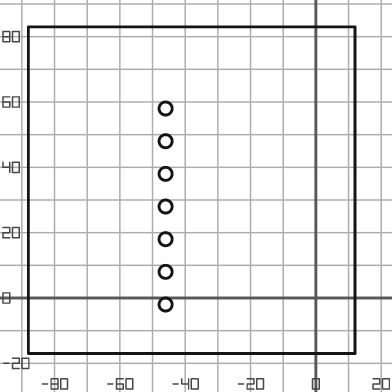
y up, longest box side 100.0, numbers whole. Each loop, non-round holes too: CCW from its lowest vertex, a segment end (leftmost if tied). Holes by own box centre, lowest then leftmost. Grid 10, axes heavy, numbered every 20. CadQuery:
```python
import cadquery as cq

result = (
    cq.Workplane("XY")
    .moveTo(-88.0, -17.0)
    .lineTo(12.0, -17.0)
    .lineTo(12.0, 83.0)
    .lineTo(-88.0, 83.0)
    .close()
    .moveTo(-46.0, -2.0)
    .circle(2.0)
    .moveTo(-46.0, 8.0)
    .circle(2.0)
    .moveTo(-46.0, 18.0)
    .circle(2.0)
    .moveTo(-46.0, 28.0)
    .circle(2.0)
    .moveTo(-46.0, 38.0)
    .circle(2.0)
    .moveTo(-46.0, 48.0)
    .circle(2.0)
    .moveTo(-46.0, 58.0)
    .circle(2.0)
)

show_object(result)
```